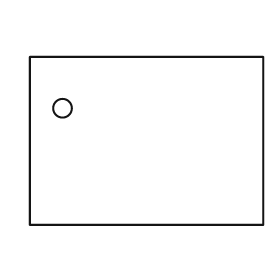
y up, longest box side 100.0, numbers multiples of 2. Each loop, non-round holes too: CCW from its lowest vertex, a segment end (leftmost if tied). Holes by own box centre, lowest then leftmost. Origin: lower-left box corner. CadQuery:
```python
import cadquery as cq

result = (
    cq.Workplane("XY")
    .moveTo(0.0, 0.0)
    .lineTo(100.0, 0.0)
    .lineTo(100.0, 72.0)
    .lineTo(0.0, 72.0)
    .close()
    .moveTo(14.0, 50.0)
    .circle(4.0)
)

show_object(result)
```